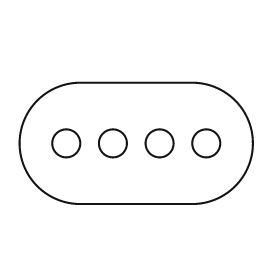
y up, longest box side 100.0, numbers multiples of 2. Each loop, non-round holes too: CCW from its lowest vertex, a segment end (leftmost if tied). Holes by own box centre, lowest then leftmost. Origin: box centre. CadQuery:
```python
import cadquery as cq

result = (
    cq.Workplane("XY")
    .moveTo(-24.0, -26.0)
    .lineTo(24.0, -26.0)
    .threePointArc((50.0, 0.0), (24.0, 26.0))
    .lineTo(-24.0, 26.0)
    .threePointArc((-50.0, 0.0), (-24.0, -26.0))
    .close()
    .moveTo(-30.0, 0.0)
    .circle(6.0)
    .moveTo(-10.0, 0.0)
    .circle(6.0)
    .moveTo(10.0, 0.0)
    .circle(6.0)
    .moveTo(30.0, 0.0)
    .circle(6.0)
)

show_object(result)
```